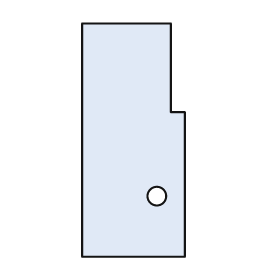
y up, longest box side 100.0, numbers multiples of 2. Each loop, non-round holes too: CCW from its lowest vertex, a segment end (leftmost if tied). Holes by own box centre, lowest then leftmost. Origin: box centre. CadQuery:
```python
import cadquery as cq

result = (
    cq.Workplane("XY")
    .moveTo(-22.0, -50.0)
    .lineTo(22.0, -50.0)
    .lineTo(22.0, 12.0)
    .lineTo(16.0, 12.0)
    .lineTo(16.0, 50.0)
    .lineTo(-22.0, 50.0)
    .close()
    .moveTo(10.0, -24.0)
    .circle(4.0)
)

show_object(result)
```